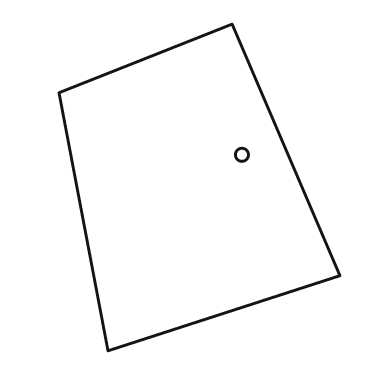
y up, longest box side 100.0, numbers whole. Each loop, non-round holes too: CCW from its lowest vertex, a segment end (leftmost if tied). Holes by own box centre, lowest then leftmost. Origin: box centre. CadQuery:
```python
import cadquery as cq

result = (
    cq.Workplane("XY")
    .moveTo(-28.0, -50.0)
    .lineTo(43.0, -27.0)
    .lineTo(10.0, 50.0)
    .lineTo(-43.0, 29.0)
    .close()
    .moveTo(13.0, 10.0)
    .circle(2.0)
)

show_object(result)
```